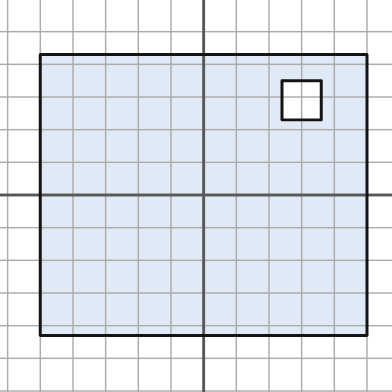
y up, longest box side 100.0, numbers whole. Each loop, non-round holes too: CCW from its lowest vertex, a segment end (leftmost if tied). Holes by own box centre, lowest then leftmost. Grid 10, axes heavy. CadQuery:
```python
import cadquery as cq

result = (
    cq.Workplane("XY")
    .moveTo(-50.0, -43.0)
    .lineTo(50.0, -43.0)
    .lineTo(50.0, 43.0)
    .lineTo(-50.0, 43.0)
    .close()
    .moveTo(24.0, 23.0)
    .lineTo(36.0, 23.0)
    .lineTo(36.0, 35.0)
    .lineTo(24.0, 35.0)
    .close()
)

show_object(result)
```